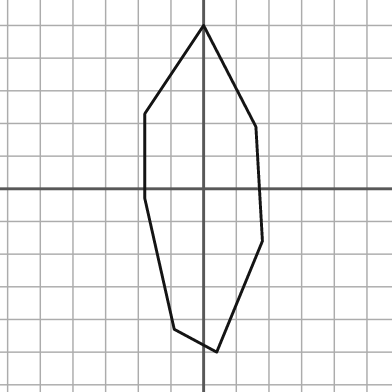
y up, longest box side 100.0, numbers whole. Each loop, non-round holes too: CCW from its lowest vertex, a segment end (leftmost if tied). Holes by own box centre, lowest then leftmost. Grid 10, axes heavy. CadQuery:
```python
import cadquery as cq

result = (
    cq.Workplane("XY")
    .moveTo(4.0, -50.0)
    .lineTo(18.0, -16.0)
    .lineTo(16.0, 19.0)
    .lineTo(0.0, 50.0)
    .lineTo(-18.0, 23.0)
    .lineTo(-18.0, -3.0)
    .lineTo(-9.0, -43.0)
    .close()
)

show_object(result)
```